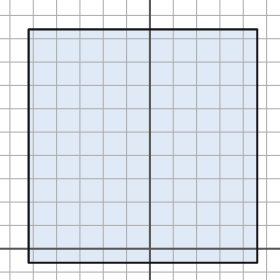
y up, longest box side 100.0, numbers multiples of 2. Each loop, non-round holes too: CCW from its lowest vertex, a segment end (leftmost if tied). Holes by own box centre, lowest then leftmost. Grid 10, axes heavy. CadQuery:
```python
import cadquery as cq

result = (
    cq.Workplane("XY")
    .moveTo(-52.0, -6.0)
    .lineTo(46.0, -6.0)
    .lineTo(46.0, 94.0)
    .lineTo(-52.0, 94.0)
    .close()
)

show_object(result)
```